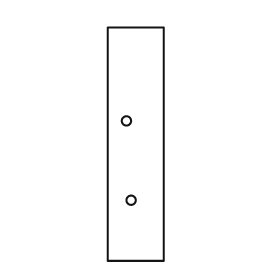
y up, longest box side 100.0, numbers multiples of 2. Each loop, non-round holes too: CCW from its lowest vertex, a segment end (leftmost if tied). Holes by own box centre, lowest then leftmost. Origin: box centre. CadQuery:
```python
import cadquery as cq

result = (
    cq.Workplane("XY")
    .moveTo(-12.0, -50.0)
    .lineTo(12.0, -50.0)
    .lineTo(12.0, 50.0)
    .lineTo(-12.0, 50.0)
    .close()
    .moveTo(-2.0, -24.0)
    .circle(2.0)
    .moveTo(-4.0, 10.0)
    .circle(2.0)
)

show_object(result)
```